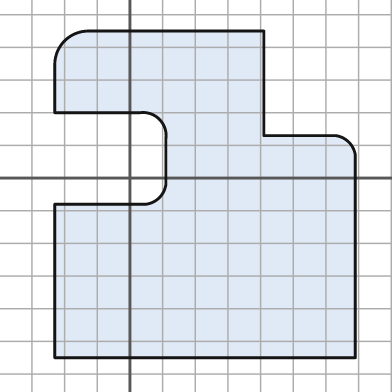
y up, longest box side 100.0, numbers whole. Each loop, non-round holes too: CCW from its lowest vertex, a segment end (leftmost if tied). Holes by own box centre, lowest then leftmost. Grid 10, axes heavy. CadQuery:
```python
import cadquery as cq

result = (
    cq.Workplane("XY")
    .moveTo(-23.0, -55.0)
    .lineTo(69.0, -55.0)
    .lineTo(69.0, 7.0)
    .threePointArc((67.0, 11.0), (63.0, 13.0))
    .lineTo(41.0, 13.0)
    .lineTo(41.0, 45.0)
    .lineTo(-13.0, 45.0)
    .threePointArc((-20.0, 42.0), (-23.0, 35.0))
    .lineTo(-23.0, 20.0)
    .lineTo(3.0, 20.0)
    .threePointArc((9.0, 18.0), (11.0, 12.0))
    .lineTo(11.0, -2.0)
    .threePointArc((9.0, -6.0), (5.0, -8.0))
    .lineTo(-23.0, -8.0)
    .close()
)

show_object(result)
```